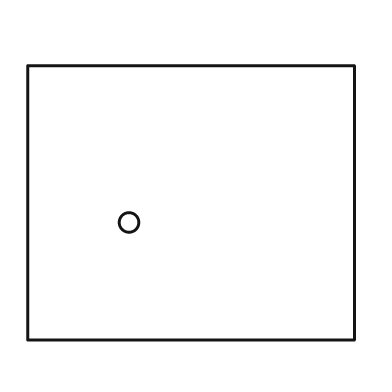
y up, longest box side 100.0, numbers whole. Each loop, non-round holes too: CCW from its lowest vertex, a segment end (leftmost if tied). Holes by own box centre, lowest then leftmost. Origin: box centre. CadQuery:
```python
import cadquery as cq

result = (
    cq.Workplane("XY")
    .moveTo(-50.0, -42.0)
    .lineTo(50.0, -42.0)
    .lineTo(50.0, 42.0)
    .lineTo(-50.0, 42.0)
    .close()
    .moveTo(-19.0, -6.0)
    .circle(3.0)
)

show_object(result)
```